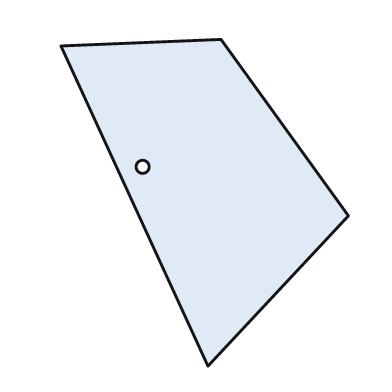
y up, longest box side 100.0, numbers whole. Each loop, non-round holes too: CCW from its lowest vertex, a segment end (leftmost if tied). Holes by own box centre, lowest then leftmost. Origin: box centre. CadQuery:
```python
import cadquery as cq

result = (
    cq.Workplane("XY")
    .moveTo(1.0, -50.0)
    .lineTo(44.0, -4.0)
    .lineTo(5.0, 50.0)
    .lineTo(-44.0, 48.0)
    .close()
    .moveTo(-19.0, 11.0)
    .circle(2.0)
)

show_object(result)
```